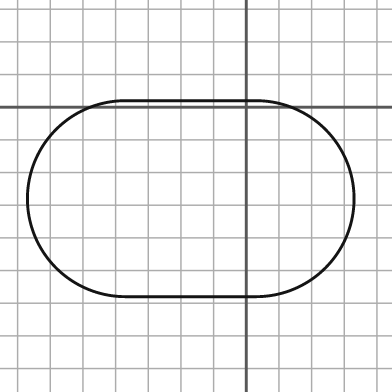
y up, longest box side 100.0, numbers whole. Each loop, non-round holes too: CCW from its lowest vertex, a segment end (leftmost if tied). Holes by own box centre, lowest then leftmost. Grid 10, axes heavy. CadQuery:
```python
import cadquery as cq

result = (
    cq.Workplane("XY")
    .moveTo(-37.0, -58.0)
    .lineTo(3.0, -58.0)
    .threePointArc((33.0, -28.0), (3.0, 2.0))
    .lineTo(-37.0, 2.0)
    .threePointArc((-67.0, -28.0), (-37.0, -58.0))
    .close()
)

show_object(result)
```